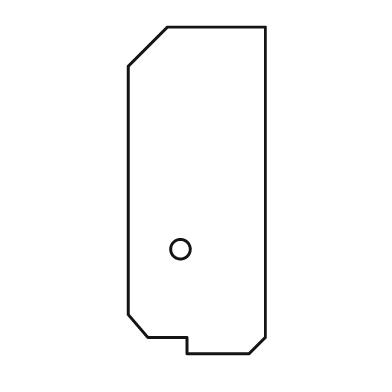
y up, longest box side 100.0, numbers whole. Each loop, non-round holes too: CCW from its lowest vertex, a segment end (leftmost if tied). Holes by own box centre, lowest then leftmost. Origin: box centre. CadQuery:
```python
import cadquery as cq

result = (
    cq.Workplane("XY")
    .moveTo(-3.0, -50.0)
    .lineTo(16.0, -50.0)
    .lineTo(21.0, -45.0)
    .lineTo(21.0, 50.0)
    .lineTo(-9.0, 50.0)
    .lineTo(-21.0, 38.0)
    .lineTo(-21.0, -38.0)
    .lineTo(-15.0, -45.0)
    .lineTo(-3.0, -45.0)
    .close()
    .moveTo(-5.0, -18.0)
    .circle(3.0)
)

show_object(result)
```